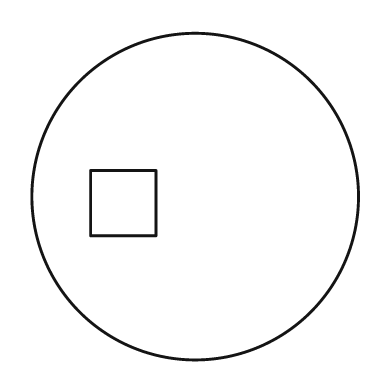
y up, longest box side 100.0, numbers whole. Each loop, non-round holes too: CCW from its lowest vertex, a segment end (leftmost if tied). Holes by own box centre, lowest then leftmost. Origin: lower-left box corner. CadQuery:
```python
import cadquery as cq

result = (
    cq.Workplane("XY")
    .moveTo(50.0, 50.0)
    .circle(50.0)
    .moveTo(18.0, 38.0)
    .lineTo(38.0, 38.0)
    .lineTo(38.0, 58.0)
    .lineTo(18.0, 58.0)
    .close()
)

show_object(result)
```